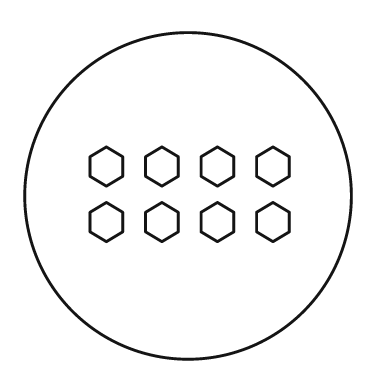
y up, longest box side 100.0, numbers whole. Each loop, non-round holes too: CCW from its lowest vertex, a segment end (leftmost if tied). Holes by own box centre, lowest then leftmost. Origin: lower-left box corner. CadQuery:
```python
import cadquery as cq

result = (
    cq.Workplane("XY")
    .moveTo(50.0, 50.0)
    .circle(50.0)
    .moveTo(25.0, 36.0)
    .lineTo(30.0, 39.0)
    .lineTo(30.0, 45.0)
    .lineTo(25.0, 48.0)
    .lineTo(20.0, 45.0)
    .lineTo(20.0, 39.0)
    .close()
    .moveTo(42.0, 36.0)
    .lineTo(47.0, 39.0)
    .lineTo(47.0, 45.0)
    .lineTo(42.0, 48.0)
    .lineTo(37.0, 45.0)
    .lineTo(37.0, 39.0)
    .close()
    .moveTo(59.0, 36.0)
    .lineTo(64.0, 39.0)
    .lineTo(64.0, 45.0)
    .lineTo(59.0, 48.0)
    .lineTo(54.0, 45.0)
    .lineTo(54.0, 39.0)
    .close()
    .moveTo(76.0, 36.0)
    .lineTo(81.0, 39.0)
    .lineTo(81.0, 45.0)
    .lineTo(76.0, 48.0)
    .lineTo(71.0, 45.0)
    .lineTo(71.0, 39.0)
    .close()
    .moveTo(25.0, 53.0)
    .lineTo(30.0, 56.0)
    .lineTo(30.0, 62.0)
    .lineTo(25.0, 65.0)
    .lineTo(20.0, 62.0)
    .lineTo(20.0, 56.0)
    .close()
    .moveTo(42.0, 53.0)
    .lineTo(47.0, 56.0)
    .lineTo(47.0, 62.0)
    .lineTo(42.0, 65.0)
    .lineTo(37.0, 62.0)
    .lineTo(37.0, 56.0)
    .close()
    .moveTo(59.0, 53.0)
    .lineTo(64.0, 56.0)
    .lineTo(64.0, 62.0)
    .lineTo(59.0, 65.0)
    .lineTo(54.0, 62.0)
    .lineTo(54.0, 56.0)
    .close()
    .moveTo(76.0, 53.0)
    .lineTo(81.0, 56.0)
    .lineTo(81.0, 62.0)
    .lineTo(76.0, 65.0)
    .lineTo(71.0, 62.0)
    .lineTo(71.0, 56.0)
    .close()
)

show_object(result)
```